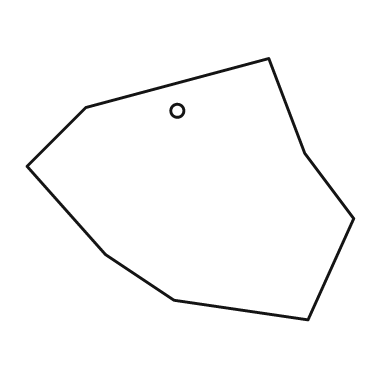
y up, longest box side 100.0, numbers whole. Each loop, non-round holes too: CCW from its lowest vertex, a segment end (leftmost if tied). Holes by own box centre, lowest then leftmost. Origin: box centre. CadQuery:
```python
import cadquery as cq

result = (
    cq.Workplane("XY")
    .moveTo(36.0, -40.0)
    .lineTo(50.0, -9.0)
    .lineTo(35.0, 11.0)
    .lineTo(24.0, 40.0)
    .lineTo(-32.0, 25.0)
    .lineTo(-50.0, 7.0)
    .lineTo(-26.0, -20.0)
    .lineTo(-5.0, -34.0)
    .close()
    .moveTo(-4.0, 24.0)
    .circle(2.0)
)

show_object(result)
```